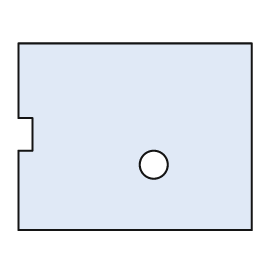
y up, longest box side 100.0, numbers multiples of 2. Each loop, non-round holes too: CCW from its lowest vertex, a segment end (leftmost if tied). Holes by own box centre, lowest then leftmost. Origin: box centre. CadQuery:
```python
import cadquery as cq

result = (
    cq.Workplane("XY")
    .moveTo(-50.0, -40.0)
    .lineTo(50.0, -40.0)
    .lineTo(50.0, 40.0)
    .lineTo(-50.0, 40.0)
    .lineTo(-50.0, 8.0)
    .lineTo(-44.0, 8.0)
    .lineTo(-44.0, -6.0)
    .lineTo(-50.0, -6.0)
    .close()
    .moveTo(8.0, -12.0)
    .circle(6.0)
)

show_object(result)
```